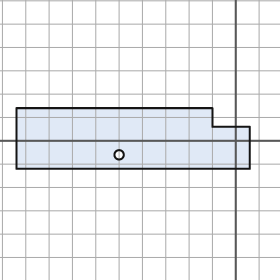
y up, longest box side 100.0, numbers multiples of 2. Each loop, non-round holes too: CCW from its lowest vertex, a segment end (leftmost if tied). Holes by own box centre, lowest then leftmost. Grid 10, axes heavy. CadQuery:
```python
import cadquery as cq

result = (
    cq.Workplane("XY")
    .moveTo(-94.0, -12.0)
    .lineTo(6.0, -12.0)
    .lineTo(6.0, 6.0)
    .lineTo(-10.0, 6.0)
    .lineTo(-10.0, 14.0)
    .lineTo(-94.0, 14.0)
    .close()
    .moveTo(-50.0, -6.0)
    .circle(2.0)
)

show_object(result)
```